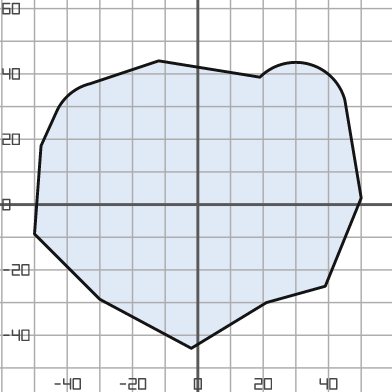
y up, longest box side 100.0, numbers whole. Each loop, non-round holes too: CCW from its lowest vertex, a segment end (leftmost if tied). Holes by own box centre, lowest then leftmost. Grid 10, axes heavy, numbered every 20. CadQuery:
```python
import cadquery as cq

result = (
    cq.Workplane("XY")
    .moveTo(-2.0, -44.0)
    .lineTo(21.0, -30.0)
    .lineTo(39.0, -25.0)
    .lineTo(50.0, 2.0)
    .lineTo(45.0, 32.0)
    .threePointArc((34.0, 43.0), (19.0, 39.0))
    .lineTo(-12.0, 44.0)
    .lineTo(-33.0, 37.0)
    .threePointArc((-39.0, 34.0), (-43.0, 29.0))
    .lineTo(-48.0, 18.0)
    .lineTo(-50.0, -9.0)
    .lineTo(-30.0, -29.0)
    .close()
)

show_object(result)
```